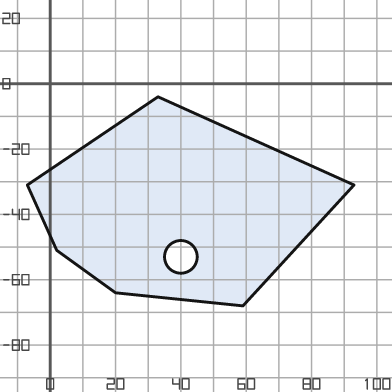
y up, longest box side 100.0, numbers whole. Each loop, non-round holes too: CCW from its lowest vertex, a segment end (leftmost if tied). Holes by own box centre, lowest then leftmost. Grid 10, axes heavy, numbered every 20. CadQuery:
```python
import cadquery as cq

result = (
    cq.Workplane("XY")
    .moveTo(59.0, -68.0)
    .lineTo(93.0, -31.0)
    .lineTo(33.0, -4.0)
    .lineTo(-7.0, -31.0)
    .lineTo(2.0, -51.0)
    .lineTo(20.0, -64.0)
    .close()
    .moveTo(40.0, -53.0)
    .circle(5.0)
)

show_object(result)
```